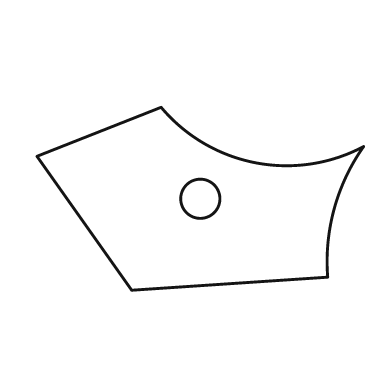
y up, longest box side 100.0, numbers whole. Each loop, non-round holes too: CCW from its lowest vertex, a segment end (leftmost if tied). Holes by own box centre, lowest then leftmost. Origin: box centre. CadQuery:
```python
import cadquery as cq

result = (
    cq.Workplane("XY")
    .moveTo(-21.0, -28.0)
    .lineTo(39.0, -24.0)
    .threePointArc((41.0, -3.0), (50.0, 16.0))
    .threePointArc((17.0, 11.0), (-12.0, 28.0))
    .lineTo(-50.0, 13.0)
    .close()
    .moveTo(0.0, 0.0)
    .circle(6.0)
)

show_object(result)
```